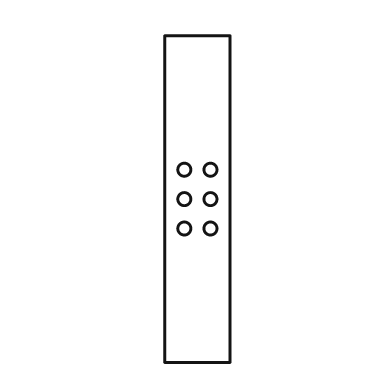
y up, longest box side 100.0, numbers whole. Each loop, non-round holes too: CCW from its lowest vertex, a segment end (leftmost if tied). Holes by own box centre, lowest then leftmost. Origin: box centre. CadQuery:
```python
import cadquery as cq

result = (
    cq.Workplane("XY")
    .moveTo(-10.0, -50.0)
    .lineTo(10.0, -50.0)
    .lineTo(10.0, 50.0)
    .lineTo(-10.0, 50.0)
    .close()
    .moveTo(-4.0, -9.0)
    .circle(2.0)
    .moveTo(4.0, -9.0)
    .circle(2.0)
    .moveTo(-4.0, 0.0)
    .circle(2.0)
    .moveTo(4.0, 0.0)
    .circle(2.0)
    .moveTo(-4.0, 9.0)
    .circle(2.0)
    .moveTo(4.0, 9.0)
    .circle(2.0)
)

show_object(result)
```